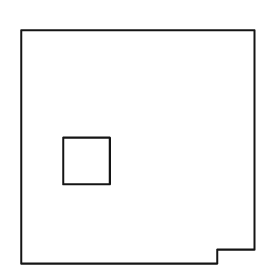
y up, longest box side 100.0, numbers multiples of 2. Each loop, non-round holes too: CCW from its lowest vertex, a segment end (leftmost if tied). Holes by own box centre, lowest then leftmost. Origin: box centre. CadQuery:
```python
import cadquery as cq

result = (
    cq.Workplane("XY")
    .moveTo(-50.0, -50.0)
    .lineTo(34.0, -50.0)
    .lineTo(34.0, -44.0)
    .lineTo(50.0, -44.0)
    .lineTo(50.0, 50.0)
    .lineTo(-50.0, 50.0)
    .close()
    .moveTo(-32.0, -16.0)
    .lineTo(-12.0, -16.0)
    .lineTo(-12.0, 4.0)
    .lineTo(-32.0, 4.0)
    .close()
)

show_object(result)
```